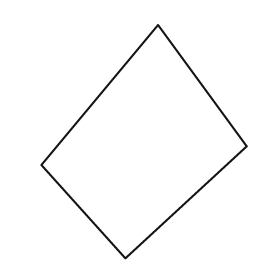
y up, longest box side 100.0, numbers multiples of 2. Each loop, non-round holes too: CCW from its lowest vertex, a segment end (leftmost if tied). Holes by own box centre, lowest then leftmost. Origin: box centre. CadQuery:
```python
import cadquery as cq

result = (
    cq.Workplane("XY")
    .moveTo(-8.0, -50.0)
    .lineTo(44.0, -2.0)
    .lineTo(6.0, 50.0)
    .lineTo(-44.0, -10.0)
    .close()
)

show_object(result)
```